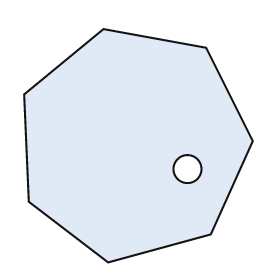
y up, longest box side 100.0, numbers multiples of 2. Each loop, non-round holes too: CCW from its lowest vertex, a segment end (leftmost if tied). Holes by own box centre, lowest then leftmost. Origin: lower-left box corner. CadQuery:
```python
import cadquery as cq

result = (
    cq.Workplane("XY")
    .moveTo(36.0, 0.0)
    .lineTo(80.0, 12.0)
    .lineTo(98.0, 52.0)
    .lineTo(78.0, 92.0)
    .lineTo(34.0, 100.0)
    .lineTo(0.0, 72.0)
    .lineTo(2.0, 26.0)
    .close()
    .moveTo(70.0, 40.0)
    .circle(6.0)
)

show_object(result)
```